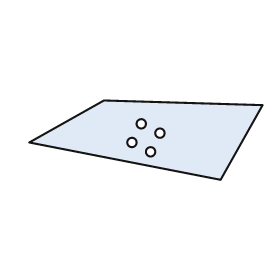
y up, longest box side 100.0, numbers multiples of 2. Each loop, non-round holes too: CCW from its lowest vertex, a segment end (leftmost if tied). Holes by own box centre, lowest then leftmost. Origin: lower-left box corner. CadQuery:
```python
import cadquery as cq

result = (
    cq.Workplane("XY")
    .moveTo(82.0, 0.0)
    .lineTo(100.0, 32.0)
    .lineTo(32.0, 34.0)
    .lineTo(0.0, 16.0)
    .close()
    .moveTo(52.0, 12.0)
    .circle(2.0)
    .moveTo(44.0, 16.0)
    .circle(2.0)
    .moveTo(56.0, 20.0)
    .circle(2.0)
    .moveTo(48.0, 24.0)
    .circle(2.0)
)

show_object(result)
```